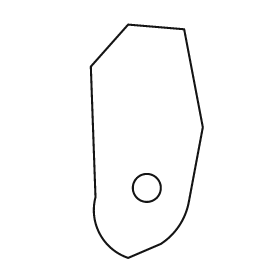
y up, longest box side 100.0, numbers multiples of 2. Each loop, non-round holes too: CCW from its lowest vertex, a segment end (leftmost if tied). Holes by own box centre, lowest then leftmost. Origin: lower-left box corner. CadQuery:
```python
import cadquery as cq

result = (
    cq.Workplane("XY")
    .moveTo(16.0, 0.0)
    .lineTo(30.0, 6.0)
    .threePointArc((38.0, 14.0), (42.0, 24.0))
    .lineTo(48.0, 56.0)
    .lineTo(40.0, 98.0)
    .lineTo(16.0, 100.0)
    .lineTo(0.0, 82.0)
    .lineTo(2.0, 26.0)
    .threePointArc((4.0, 10.0), (16.0, 0.0))
    .close()
    .moveTo(24.0, 30.0)
    .circle(6.0)
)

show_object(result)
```